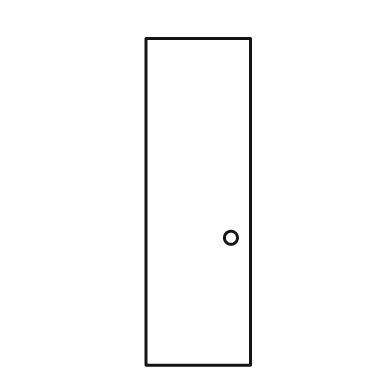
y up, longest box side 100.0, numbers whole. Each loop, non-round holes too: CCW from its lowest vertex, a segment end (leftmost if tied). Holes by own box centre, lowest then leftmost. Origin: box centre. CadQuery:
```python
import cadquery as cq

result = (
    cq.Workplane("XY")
    .moveTo(-16.0, -50.0)
    .lineTo(16.0, -50.0)
    .lineTo(16.0, 50.0)
    .lineTo(-16.0, 50.0)
    .close()
    .moveTo(10.0, -11.0)
    .circle(2.0)
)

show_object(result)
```